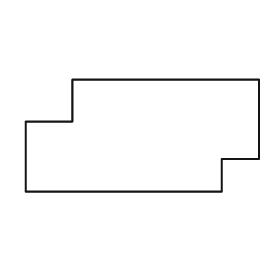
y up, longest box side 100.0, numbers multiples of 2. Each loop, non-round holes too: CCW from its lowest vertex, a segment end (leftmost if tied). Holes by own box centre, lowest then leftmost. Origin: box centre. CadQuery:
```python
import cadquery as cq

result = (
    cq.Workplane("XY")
    .moveTo(-50.0, -24.0)
    .lineTo(34.0, -24.0)
    .lineTo(34.0, -10.0)
    .lineTo(50.0, -10.0)
    .lineTo(50.0, 24.0)
    .lineTo(-30.0, 24.0)
    .lineTo(-30.0, 6.0)
    .lineTo(-50.0, 6.0)
    .close()
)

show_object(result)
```